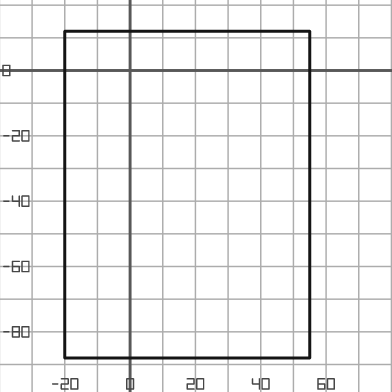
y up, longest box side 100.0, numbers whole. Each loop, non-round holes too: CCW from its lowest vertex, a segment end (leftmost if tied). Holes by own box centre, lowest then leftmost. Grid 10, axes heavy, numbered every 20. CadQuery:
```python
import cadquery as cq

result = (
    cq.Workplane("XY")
    .moveTo(-20.0, -88.0)
    .lineTo(55.0, -88.0)
    .lineTo(55.0, 12.0)
    .lineTo(-20.0, 12.0)
    .close()
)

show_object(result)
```